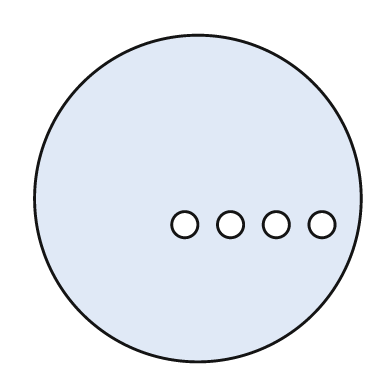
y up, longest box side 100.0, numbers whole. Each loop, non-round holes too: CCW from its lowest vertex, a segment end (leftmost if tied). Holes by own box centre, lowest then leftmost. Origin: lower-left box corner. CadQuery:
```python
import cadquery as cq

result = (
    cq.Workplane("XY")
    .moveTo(50.0, 50.0)
    .circle(50.0)
    .moveTo(46.0, 42.0)
    .circle(4.0)
    .moveTo(60.0, 42.0)
    .circle(4.0)
    .moveTo(74.0, 42.0)
    .circle(4.0)
    .moveTo(88.0, 42.0)
    .circle(4.0)
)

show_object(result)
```